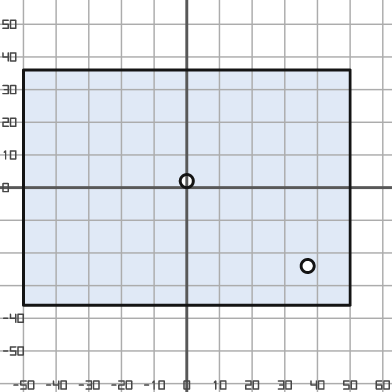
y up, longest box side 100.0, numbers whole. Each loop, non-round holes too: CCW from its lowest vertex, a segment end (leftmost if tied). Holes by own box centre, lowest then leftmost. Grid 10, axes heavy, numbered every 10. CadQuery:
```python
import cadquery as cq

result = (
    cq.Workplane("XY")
    .moveTo(-50.0, -36.0)
    .lineTo(50.0, -36.0)
    .lineTo(50.0, 36.0)
    .lineTo(-50.0, 36.0)
    .close()
    .moveTo(37.0, -24.0)
    .circle(2.0)
    .moveTo(0.0, 2.0)
    .circle(2.0)
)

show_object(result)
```